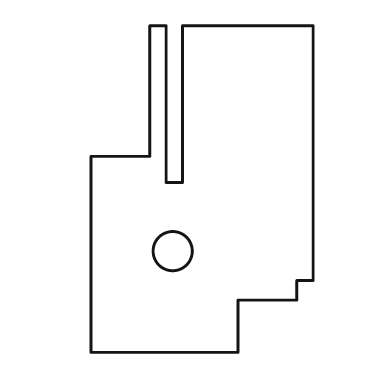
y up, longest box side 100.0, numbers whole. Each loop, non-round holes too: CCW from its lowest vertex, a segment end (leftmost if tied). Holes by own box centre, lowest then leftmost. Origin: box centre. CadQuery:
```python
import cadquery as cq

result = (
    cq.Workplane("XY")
    .moveTo(-34.0, -50.0)
    .lineTo(11.0, -50.0)
    .lineTo(11.0, -34.0)
    .lineTo(29.0, -34.0)
    .lineTo(29.0, -28.0)
    .lineTo(34.0, -28.0)
    .lineTo(34.0, 50.0)
    .lineTo(-6.0, 50.0)
    .lineTo(-6.0, 2.0)
    .lineTo(-11.0, 2.0)
    .lineTo(-11.0, 50.0)
    .lineTo(-16.0, 50.0)
    .lineTo(-16.0, 10.0)
    .lineTo(-34.0, 10.0)
    .close()
    .moveTo(-9.0, -19.0)
    .circle(6.0)
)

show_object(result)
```